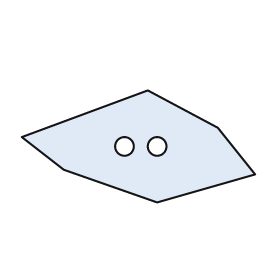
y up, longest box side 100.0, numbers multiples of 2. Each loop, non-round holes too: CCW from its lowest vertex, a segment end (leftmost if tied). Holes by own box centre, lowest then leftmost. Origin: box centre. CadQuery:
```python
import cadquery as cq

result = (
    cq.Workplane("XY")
    .moveTo(8.0, -24.0)
    .lineTo(50.0, -12.0)
    .lineTo(34.0, 8.0)
    .lineTo(4.0, 24.0)
    .lineTo(-50.0, 4.0)
    .lineTo(-32.0, -10.0)
    .close()
    .moveTo(-6.0, 0.0)
    .circle(4.0)
    .moveTo(8.0, 0.0)
    .circle(4.0)
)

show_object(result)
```